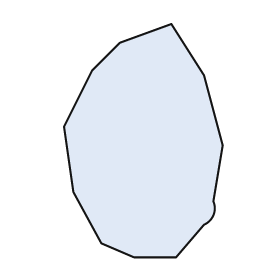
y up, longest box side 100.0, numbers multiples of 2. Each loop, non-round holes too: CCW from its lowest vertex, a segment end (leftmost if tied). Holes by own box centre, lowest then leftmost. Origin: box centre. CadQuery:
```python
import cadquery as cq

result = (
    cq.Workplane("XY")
    .moveTo(-4.0, -50.0)
    .lineTo(14.0, -50.0)
    .lineTo(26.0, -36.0)
    .threePointArc((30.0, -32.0), (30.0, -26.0))
    .lineTo(34.0, -2.0)
    .lineTo(26.0, 28.0)
    .lineTo(12.0, 50.0)
    .lineTo(-10.0, 42.0)
    .lineTo(-22.0, 30.0)
    .lineTo(-34.0, 6.0)
    .lineTo(-30.0, -22.0)
    .lineTo(-18.0, -44.0)
    .close()
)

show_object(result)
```